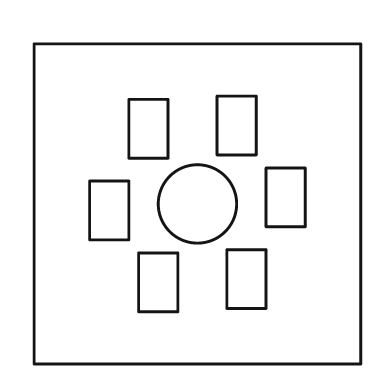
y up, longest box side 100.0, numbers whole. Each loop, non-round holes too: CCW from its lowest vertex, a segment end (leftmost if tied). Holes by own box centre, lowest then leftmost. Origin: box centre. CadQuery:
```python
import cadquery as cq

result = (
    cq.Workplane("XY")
    .moveTo(-50.0, -49.0)
    .lineTo(50.0, -49.0)
    .lineTo(50.0, 49.0)
    .lineTo(-50.0, 49.0)
    .close()
    .moveTo(-18.0, -33.0)
    .lineTo(-6.0, -33.0)
    .lineTo(-6.0, -15.0)
    .lineTo(-18.0, -15.0)
    .close()
    .moveTo(9.0, -32.0)
    .lineTo(21.0, -32.0)
    .lineTo(21.0, -14.0)
    .lineTo(9.0, -14.0)
    .close()
    .moveTo(-33.0, -11.0)
    .lineTo(-21.0, -11.0)
    .lineTo(-21.0, 7.0)
    .lineTo(-33.0, 7.0)
    .close()
    .moveTo(0.0, 0.0)
    .circle(12.0)
    .moveTo(21.0, -7.0)
    .lineTo(33.0, -7.0)
    .lineTo(33.0, 11.0)
    .lineTo(21.0, 11.0)
    .close()
    .moveTo(-21.0, 14.0)
    .lineTo(-9.0, 14.0)
    .lineTo(-9.0, 32.0)
    .lineTo(-21.0, 32.0)
    .close()
    .moveTo(6.0, 15.0)
    .lineTo(18.0, 15.0)
    .lineTo(18.0, 33.0)
    .lineTo(6.0, 33.0)
    .close()
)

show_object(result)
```